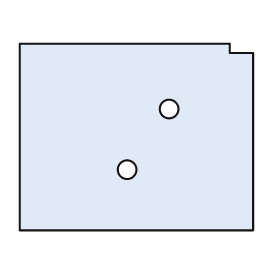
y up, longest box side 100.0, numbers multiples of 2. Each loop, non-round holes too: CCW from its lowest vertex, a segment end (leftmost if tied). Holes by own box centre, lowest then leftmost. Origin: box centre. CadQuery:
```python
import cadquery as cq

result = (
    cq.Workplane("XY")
    .moveTo(-50.0, -40.0)
    .lineTo(50.0, -40.0)
    .lineTo(50.0, 36.0)
    .lineTo(40.0, 36.0)
    .lineTo(40.0, 40.0)
    .lineTo(-50.0, 40.0)
    .close()
    .moveTo(-4.0, -14.0)
    .circle(4.0)
    .moveTo(14.0, 12.0)
    .circle(4.0)
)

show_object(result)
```